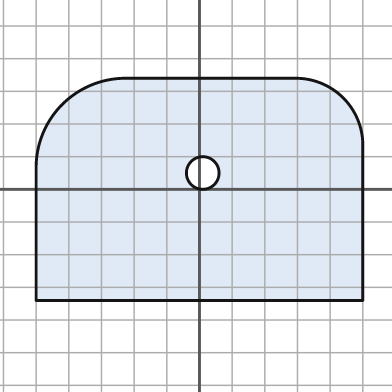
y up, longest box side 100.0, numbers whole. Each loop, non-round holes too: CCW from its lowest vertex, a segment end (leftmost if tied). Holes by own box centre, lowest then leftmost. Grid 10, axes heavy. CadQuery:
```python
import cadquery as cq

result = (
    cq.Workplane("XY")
    .moveTo(-50.0, -34.0)
    .lineTo(50.0, -34.0)
    .lineTo(50.0, 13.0)
    .threePointArc((44.0, 28.0), (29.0, 34.0))
    .lineTo(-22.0, 34.0)
    .threePointArc((-42.0, 26.0), (-50.0, 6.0))
    .close()
    .moveTo(1.0, 5.0)
    .circle(5.0)
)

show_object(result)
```